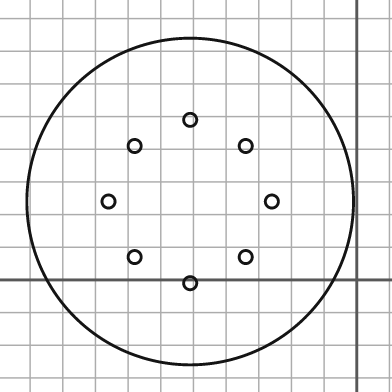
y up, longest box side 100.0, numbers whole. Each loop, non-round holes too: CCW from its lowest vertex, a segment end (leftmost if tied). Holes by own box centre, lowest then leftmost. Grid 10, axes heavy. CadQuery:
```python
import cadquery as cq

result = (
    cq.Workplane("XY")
    .moveTo(-51.0, 24.0)
    .circle(50.0)
    .moveTo(-51.0, -1.0)
    .circle(2.0)
    .moveTo(-68.0, 7.0)
    .circle(2.0)
    .moveTo(-34.0, 7.0)
    .circle(2.0)
    .moveTo(-76.0, 24.0)
    .circle(2.0)
    .moveTo(-26.0, 24.0)
    .circle(2.0)
    .moveTo(-68.0, 41.0)
    .circle(2.0)
    .moveTo(-34.0, 41.0)
    .circle(2.0)
    .moveTo(-51.0, 49.0)
    .circle(2.0)
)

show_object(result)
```